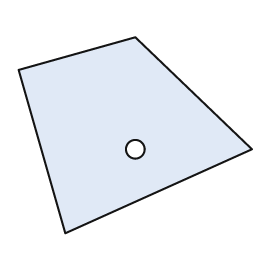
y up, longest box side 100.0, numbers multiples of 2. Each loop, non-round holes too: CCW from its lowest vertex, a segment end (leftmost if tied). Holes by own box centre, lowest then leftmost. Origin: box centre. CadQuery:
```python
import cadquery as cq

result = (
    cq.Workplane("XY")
    .moveTo(-30.0, -42.0)
    .lineTo(50.0, -6.0)
    .lineTo(0.0, 42.0)
    .lineTo(-50.0, 28.0)
    .close()
    .moveTo(0.0, -6.0)
    .circle(4.0)
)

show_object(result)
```